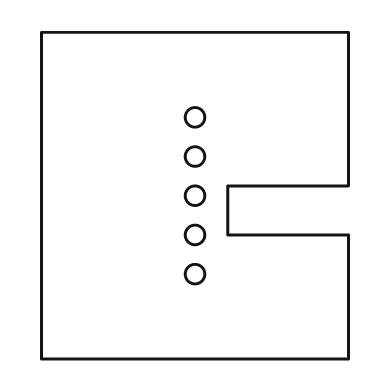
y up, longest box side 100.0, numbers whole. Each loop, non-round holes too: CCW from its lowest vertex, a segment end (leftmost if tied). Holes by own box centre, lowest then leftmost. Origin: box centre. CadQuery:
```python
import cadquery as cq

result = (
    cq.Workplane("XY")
    .moveTo(-47.0, -50.0)
    .lineTo(47.0, -50.0)
    .lineTo(47.0, -12.0)
    .lineTo(10.0, -12.0)
    .lineTo(10.0, 3.0)
    .lineTo(47.0, 3.0)
    .lineTo(47.0, 50.0)
    .lineTo(-47.0, 50.0)
    .close()
    .moveTo(0.0, -24.0)
    .circle(3.0)
    .moveTo(0.0, -12.0)
    .circle(3.0)
    .moveTo(0.0, 0.0)
    .circle(3.0)
    .moveTo(0.0, 12.0)
    .circle(3.0)
    .moveTo(0.0, 24.0)
    .circle(3.0)
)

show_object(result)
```